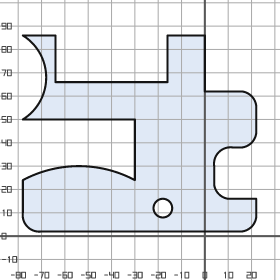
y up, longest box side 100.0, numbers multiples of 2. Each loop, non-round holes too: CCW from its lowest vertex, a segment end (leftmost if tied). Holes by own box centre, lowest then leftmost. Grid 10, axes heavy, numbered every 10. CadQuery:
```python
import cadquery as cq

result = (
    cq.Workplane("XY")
    .moveTo(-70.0, 2.0)
    .lineTo(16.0, 2.0)
    .threePointArc((20.0, 4.0), (22.0, 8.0))
    .lineTo(22.0, 16.0)
    .lineTo(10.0, 16.0)
    .threePointArc((6.0, 18.0), (4.0, 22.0))
    .lineTo(4.0, 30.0)
    .threePointArc((6.0, 36.0), (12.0, 38.0))
    .lineTo(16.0, 38.0)
    .threePointArc((20.0, 40.0), (22.0, 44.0))
    .lineTo(22.0, 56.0)
    .threePointArc((20.0, 60.0), (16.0, 62.0))
    .lineTo(0.0, 62.0)
    .lineTo(0.0, 86.0)
    .lineTo(-16.0, 86.0)
    .lineTo(-16.0, 66.0)
    .lineTo(-64.0, 66.0)
    .lineTo(-64.0, 86.0)
    .lineTo(-78.0, 86.0)
    .threePointArc((-68.0, 68.0), (-78.0, 50.0))
    .lineTo(-30.0, 50.0)
    .lineTo(-30.0, 24.0)
    .threePointArc((-54.0, 30.0), (-78.0, 24.0))
    .lineTo(-78.0, 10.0)
    .threePointArc((-76.0, 4.0), (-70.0, 2.0))
    .close()
    .moveTo(-18.0, 12.0)
    .circle(4.0)
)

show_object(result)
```